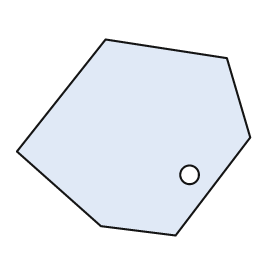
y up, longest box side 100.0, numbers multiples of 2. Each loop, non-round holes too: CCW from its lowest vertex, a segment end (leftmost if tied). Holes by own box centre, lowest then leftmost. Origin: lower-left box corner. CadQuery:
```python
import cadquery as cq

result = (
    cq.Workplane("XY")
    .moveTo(68.0, 0.0)
    .lineTo(100.0, 42.0)
    .lineTo(90.0, 76.0)
    .lineTo(38.0, 84.0)
    .lineTo(0.0, 36.0)
    .lineTo(36.0, 4.0)
    .close()
    .moveTo(74.0, 26.0)
    .circle(4.0)
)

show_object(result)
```